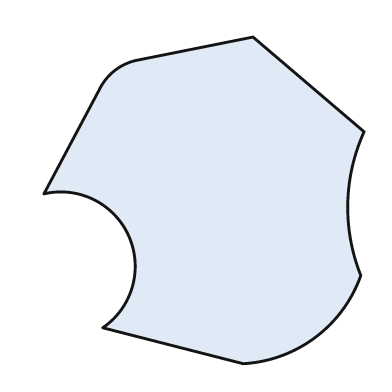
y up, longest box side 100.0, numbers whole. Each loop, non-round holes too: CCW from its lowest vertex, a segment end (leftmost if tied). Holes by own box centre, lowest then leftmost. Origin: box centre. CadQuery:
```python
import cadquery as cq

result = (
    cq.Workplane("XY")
    .moveTo(12.0, -50.0)
    .threePointArc((34.0, -42.0), (48.0, -23.0))
    .threePointArc((44.0, -1.0), (49.0, 21.0))
    .lineTo(15.0, 50.0)
    .lineTo(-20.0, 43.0)
    .threePointArc((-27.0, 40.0), (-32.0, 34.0))
    .lineTo(-49.0, 2.0)
    .threePointArc((-23.0, -11.0), (-31.0, -39.0))
    .close()
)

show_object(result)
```